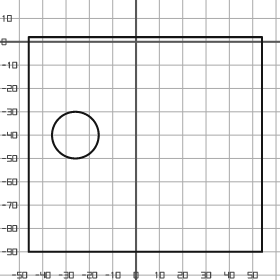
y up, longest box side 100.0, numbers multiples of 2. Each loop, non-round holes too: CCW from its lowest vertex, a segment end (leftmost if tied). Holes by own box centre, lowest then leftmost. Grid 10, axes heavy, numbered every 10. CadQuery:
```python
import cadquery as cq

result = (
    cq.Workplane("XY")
    .moveTo(-46.0, -90.0)
    .lineTo(54.0, -90.0)
    .lineTo(54.0, 2.0)
    .lineTo(-46.0, 2.0)
    .close()
    .moveTo(-26.0, -40.0)
    .circle(10.0)
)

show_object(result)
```